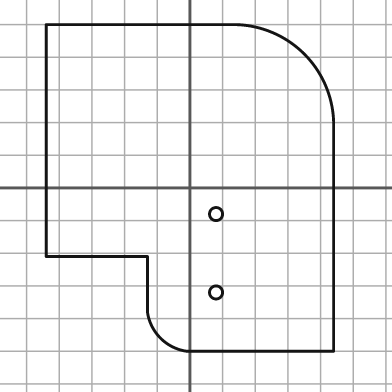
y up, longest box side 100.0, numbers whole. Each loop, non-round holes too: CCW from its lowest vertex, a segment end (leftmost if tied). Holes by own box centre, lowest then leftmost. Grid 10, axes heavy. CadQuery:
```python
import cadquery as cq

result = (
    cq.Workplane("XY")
    .moveTo(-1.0, -50.0)
    .lineTo(44.0, -50.0)
    .lineTo(44.0, 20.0)
    .threePointArc((35.0, 41.0), (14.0, 50.0))
    .lineTo(-44.0, 50.0)
    .lineTo(-44.0, -21.0)
    .lineTo(-13.0, -21.0)
    .lineTo(-13.0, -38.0)
    .threePointArc((-9.0, -46.0), (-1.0, -50.0))
    .close()
    .moveTo(8.0, -32.0)
    .circle(2.0)
    .moveTo(8.0, -8.0)
    .circle(2.0)
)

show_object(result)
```